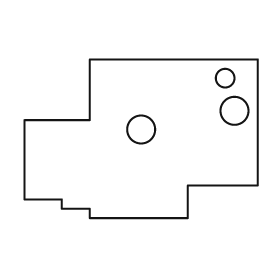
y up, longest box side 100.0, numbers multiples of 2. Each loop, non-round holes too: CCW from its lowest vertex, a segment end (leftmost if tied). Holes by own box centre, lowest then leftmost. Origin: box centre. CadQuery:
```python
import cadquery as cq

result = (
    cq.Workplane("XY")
    .moveTo(-22.0, -34.0)
    .lineTo(20.0, -34.0)
    .lineTo(20.0, -20.0)
    .lineTo(50.0, -20.0)
    .lineTo(50.0, 34.0)
    .lineTo(-22.0, 34.0)
    .lineTo(-22.0, 8.0)
    .lineTo(-50.0, 8.0)
    .lineTo(-50.0, -26.0)
    .lineTo(-34.0, -26.0)
    .lineTo(-34.0, -30.0)
    .lineTo(-22.0, -30.0)
    .close()
    .moveTo(0.0, 4.0)
    .circle(6.0)
    .moveTo(40.0, 12.0)
    .circle(6.0)
    .moveTo(36.0, 26.0)
    .circle(4.0)
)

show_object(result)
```